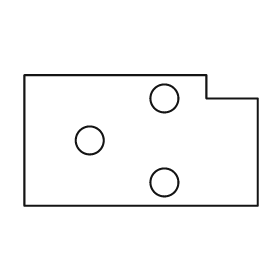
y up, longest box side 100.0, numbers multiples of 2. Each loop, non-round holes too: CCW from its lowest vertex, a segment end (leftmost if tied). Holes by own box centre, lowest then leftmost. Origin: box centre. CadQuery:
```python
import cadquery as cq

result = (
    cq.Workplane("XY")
    .moveTo(-50.0, -28.0)
    .lineTo(50.0, -28.0)
    .lineTo(50.0, 18.0)
    .lineTo(28.0, 18.0)
    .lineTo(28.0, 28.0)
    .lineTo(-50.0, 28.0)
    .close()
    .moveTo(10.0, -18.0)
    .circle(6.0)
    .moveTo(-22.0, 0.0)
    .circle(6.0)
    .moveTo(10.0, 18.0)
    .circle(6.0)
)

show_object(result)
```